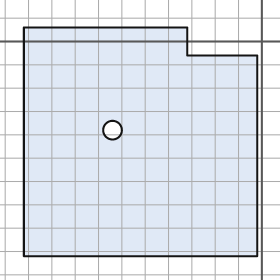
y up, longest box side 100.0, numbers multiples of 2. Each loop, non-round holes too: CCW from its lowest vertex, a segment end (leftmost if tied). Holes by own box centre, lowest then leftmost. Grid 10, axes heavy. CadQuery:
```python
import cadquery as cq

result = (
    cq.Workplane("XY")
    .moveTo(-102.0, -92.0)
    .lineTo(-2.0, -92.0)
    .lineTo(-2.0, -6.0)
    .lineTo(-32.0, -6.0)
    .lineTo(-32.0, 6.0)
    .lineTo(-102.0, 6.0)
    .close()
    .moveTo(-64.0, -38.0)
    .circle(4.0)
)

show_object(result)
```